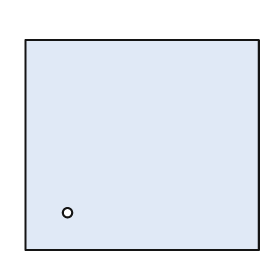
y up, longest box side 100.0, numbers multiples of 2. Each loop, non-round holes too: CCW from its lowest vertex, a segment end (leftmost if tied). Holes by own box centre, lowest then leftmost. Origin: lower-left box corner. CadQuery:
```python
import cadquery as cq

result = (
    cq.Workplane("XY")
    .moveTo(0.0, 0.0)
    .lineTo(100.0, 0.0)
    .lineTo(100.0, 90.0)
    .lineTo(0.0, 90.0)
    .close()
    .moveTo(18.0, 16.0)
    .circle(2.0)
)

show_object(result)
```